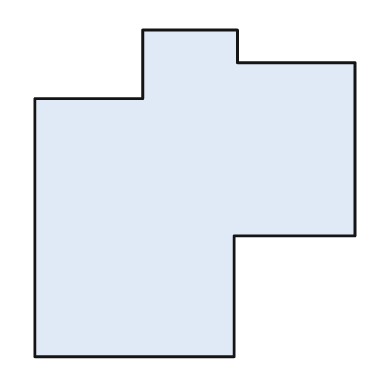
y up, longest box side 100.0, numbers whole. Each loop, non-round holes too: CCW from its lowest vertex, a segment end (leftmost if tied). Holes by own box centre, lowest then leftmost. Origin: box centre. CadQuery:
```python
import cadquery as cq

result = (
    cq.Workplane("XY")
    .moveTo(-49.0, -50.0)
    .lineTo(12.0, -50.0)
    .lineTo(12.0, -13.0)
    .lineTo(49.0, -13.0)
    .lineTo(49.0, 40.0)
    .lineTo(13.0, 40.0)
    .lineTo(13.0, 50.0)
    .lineTo(-16.0, 50.0)
    .lineTo(-16.0, 29.0)
    .lineTo(-49.0, 29.0)
    .close()
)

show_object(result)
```